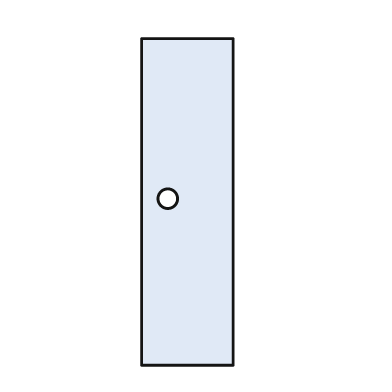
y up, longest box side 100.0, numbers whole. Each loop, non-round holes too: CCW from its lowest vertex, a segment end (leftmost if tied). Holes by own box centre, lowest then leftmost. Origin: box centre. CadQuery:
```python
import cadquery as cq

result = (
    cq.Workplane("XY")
    .moveTo(-14.0, -50.0)
    .lineTo(14.0, -50.0)
    .lineTo(14.0, 50.0)
    .lineTo(-14.0, 50.0)
    .close()
    .moveTo(-6.0, 1.0)
    .circle(3.0)
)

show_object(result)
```